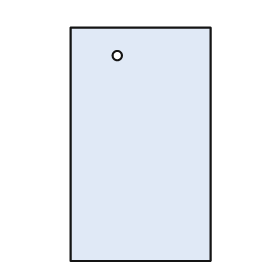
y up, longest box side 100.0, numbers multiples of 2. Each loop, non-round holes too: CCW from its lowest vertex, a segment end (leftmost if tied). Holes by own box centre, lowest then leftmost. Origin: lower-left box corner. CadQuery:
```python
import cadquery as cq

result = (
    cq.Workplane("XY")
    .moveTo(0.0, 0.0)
    .lineTo(60.0, 0.0)
    .lineTo(60.0, 100.0)
    .lineTo(0.0, 100.0)
    .close()
    .moveTo(20.0, 88.0)
    .circle(2.0)
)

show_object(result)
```